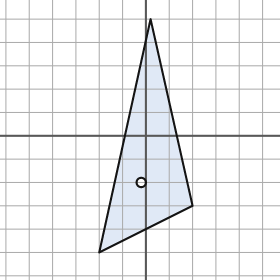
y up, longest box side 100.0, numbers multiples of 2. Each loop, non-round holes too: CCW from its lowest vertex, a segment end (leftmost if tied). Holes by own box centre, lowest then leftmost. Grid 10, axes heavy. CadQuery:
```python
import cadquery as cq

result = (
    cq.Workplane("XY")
    .moveTo(-20.0, -50.0)
    .lineTo(20.0, -30.0)
    .lineTo(2.0, 50.0)
    .close()
    .moveTo(-2.0, -20.0)
    .circle(2.0)
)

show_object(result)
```